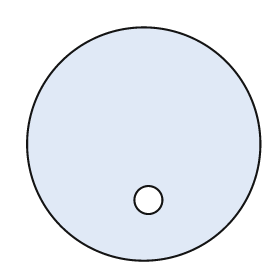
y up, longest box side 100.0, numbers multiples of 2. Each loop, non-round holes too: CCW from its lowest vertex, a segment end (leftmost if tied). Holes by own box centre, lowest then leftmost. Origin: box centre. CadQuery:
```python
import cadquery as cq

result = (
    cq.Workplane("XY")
    .moveTo(0.0, 0.0)
    .circle(50.0)
    .moveTo(2.0, -24.0)
    .circle(6.0)
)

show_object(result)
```